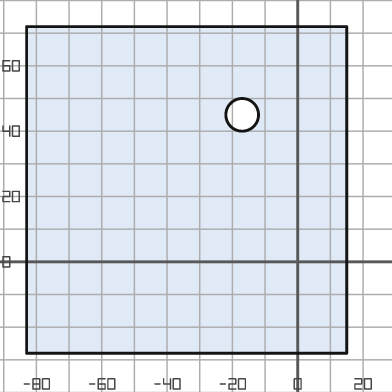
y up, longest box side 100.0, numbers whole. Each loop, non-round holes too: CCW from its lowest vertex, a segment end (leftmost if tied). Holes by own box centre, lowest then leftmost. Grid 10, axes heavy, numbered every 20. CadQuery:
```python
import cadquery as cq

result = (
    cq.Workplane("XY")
    .moveTo(-83.0, -28.0)
    .lineTo(15.0, -28.0)
    .lineTo(15.0, 72.0)
    .lineTo(-83.0, 72.0)
    .close()
    .moveTo(-17.0, 45.0)
    .circle(5.0)
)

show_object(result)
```